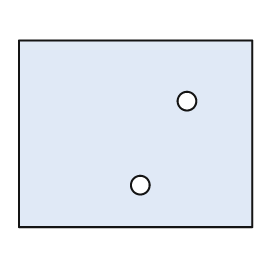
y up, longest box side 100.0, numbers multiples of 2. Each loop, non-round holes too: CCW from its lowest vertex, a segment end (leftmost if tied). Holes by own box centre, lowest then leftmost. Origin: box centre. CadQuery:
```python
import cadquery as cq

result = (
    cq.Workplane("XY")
    .moveTo(-50.0, -40.0)
    .lineTo(50.0, -40.0)
    .lineTo(50.0, 40.0)
    .lineTo(-50.0, 40.0)
    .close()
    .moveTo(2.0, -22.0)
    .circle(4.0)
    .moveTo(22.0, 14.0)
    .circle(4.0)
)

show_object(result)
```